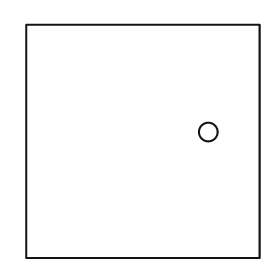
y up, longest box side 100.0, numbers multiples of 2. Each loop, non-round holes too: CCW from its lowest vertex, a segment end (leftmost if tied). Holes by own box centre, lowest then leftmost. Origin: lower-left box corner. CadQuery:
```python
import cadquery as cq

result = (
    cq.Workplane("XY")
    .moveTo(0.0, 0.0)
    .lineTo(100.0, 0.0)
    .lineTo(100.0, 100.0)
    .lineTo(0.0, 100.0)
    .close()
    .moveTo(78.0, 54.0)
    .circle(4.0)
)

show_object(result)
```